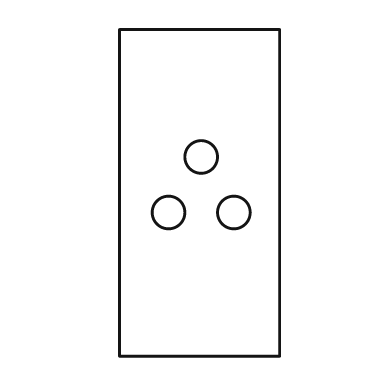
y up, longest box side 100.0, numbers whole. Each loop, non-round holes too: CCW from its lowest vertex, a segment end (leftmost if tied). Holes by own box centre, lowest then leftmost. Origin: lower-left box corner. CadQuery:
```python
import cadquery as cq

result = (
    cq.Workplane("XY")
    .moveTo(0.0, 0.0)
    .lineTo(49.0, 0.0)
    .lineTo(49.0, 100.0)
    .lineTo(0.0, 100.0)
    .close()
    .moveTo(15.0, 44.0)
    .circle(5.0)
    .moveTo(35.0, 44.0)
    .circle(5.0)
    .moveTo(25.0, 61.0)
    .circle(5.0)
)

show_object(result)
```